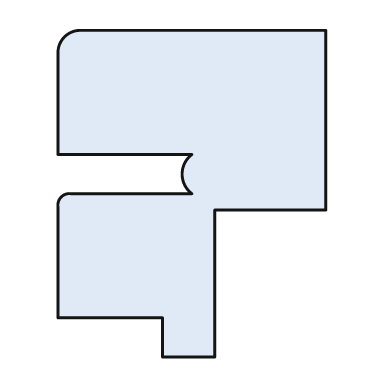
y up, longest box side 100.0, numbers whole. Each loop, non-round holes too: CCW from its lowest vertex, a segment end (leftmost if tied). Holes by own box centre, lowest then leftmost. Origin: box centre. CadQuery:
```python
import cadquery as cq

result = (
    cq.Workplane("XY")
    .moveTo(-9.0, -50.0)
    .lineTo(7.0, -50.0)
    .lineTo(7.0, -5.0)
    .lineTo(41.0, -5.0)
    .lineTo(41.0, 50.0)
    .lineTo(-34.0, 50.0)
    .threePointArc((-39.0, 48.0), (-41.0, 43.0))
    .lineTo(-41.0, 12.0)
    .lineTo(0.0, 12.0)
    .threePointArc((-3.0, 6.0), (0.0, 0.0))
    .lineTo(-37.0, 0.0)
    .threePointArc((-40.0, -1.0), (-41.0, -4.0))
    .lineTo(-41.0, -38.0)
    .lineTo(-9.0, -38.0)
    .close()
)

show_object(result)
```